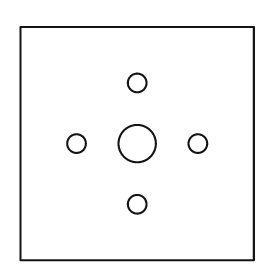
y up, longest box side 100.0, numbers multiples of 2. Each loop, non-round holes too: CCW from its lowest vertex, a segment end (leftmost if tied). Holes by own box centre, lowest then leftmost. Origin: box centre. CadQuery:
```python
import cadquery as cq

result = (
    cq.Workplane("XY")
    .moveTo(-50.0, -50.0)
    .lineTo(50.0, -50.0)
    .lineTo(50.0, 50.0)
    .lineTo(-50.0, 50.0)
    .close()
    .moveTo(0.0, -26.0)
    .circle(4.0)
    .moveTo(-26.0, 0.0)
    .circle(4.0)
    .moveTo(0.0, 0.0)
    .circle(8.0)
    .moveTo(26.0, 0.0)
    .circle(4.0)
    .moveTo(0.0, 26.0)
    .circle(4.0)
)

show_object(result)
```